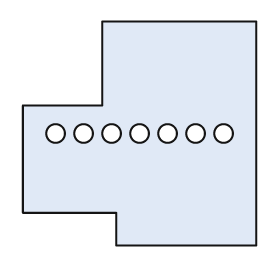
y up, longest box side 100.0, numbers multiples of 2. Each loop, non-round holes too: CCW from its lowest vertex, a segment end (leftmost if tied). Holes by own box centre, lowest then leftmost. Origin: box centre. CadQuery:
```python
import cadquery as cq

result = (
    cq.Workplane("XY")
    .moveTo(-10.0, -48.0)
    .lineTo(50.0, -48.0)
    .lineTo(50.0, 48.0)
    .lineTo(-16.0, 48.0)
    .lineTo(-16.0, 12.0)
    .lineTo(-50.0, 12.0)
    .lineTo(-50.0, -34.0)
    .lineTo(-10.0, -34.0)
    .close()
    .moveTo(-36.0, 0.0)
    .circle(4.0)
    .moveTo(-24.0, 0.0)
    .circle(4.0)
    .moveTo(-12.0, 0.0)
    .circle(4.0)
    .moveTo(0.0, 0.0)
    .circle(4.0)
    .moveTo(12.0, 0.0)
    .circle(4.0)
    .moveTo(24.0, 0.0)
    .circle(4.0)
    .moveTo(36.0, 0.0)
    .circle(4.0)
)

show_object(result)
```